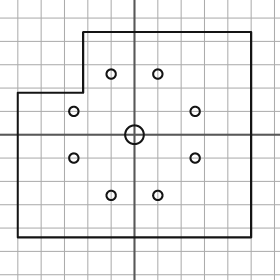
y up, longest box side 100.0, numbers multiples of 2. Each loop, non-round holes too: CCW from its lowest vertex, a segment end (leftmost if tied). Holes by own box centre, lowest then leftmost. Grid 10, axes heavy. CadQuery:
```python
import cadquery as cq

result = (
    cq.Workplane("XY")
    .moveTo(-50.0, -44.0)
    .lineTo(50.0, -44.0)
    .lineTo(50.0, 44.0)
    .lineTo(-22.0, 44.0)
    .lineTo(-22.0, 18.0)
    .lineTo(-50.0, 18.0)
    .close()
    .moveTo(-10.0, -26.0)
    .circle(2.0)
    .moveTo(10.0, -26.0)
    .circle(2.0)
    .moveTo(-26.0, -10.0)
    .circle(2.0)
    .moveTo(26.0, -10.0)
    .circle(2.0)
    .moveTo(0.0, 0.0)
    .circle(4.0)
    .moveTo(-26.0, 10.0)
    .circle(2.0)
    .moveTo(26.0, 10.0)
    .circle(2.0)
    .moveTo(-10.0, 26.0)
    .circle(2.0)
    .moveTo(10.0, 26.0)
    .circle(2.0)
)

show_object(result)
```